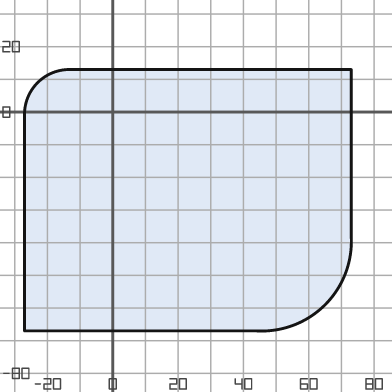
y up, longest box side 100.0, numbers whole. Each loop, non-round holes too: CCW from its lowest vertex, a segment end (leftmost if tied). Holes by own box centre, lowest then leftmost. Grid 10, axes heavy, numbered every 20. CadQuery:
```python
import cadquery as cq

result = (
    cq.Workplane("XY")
    .moveTo(-27.0, -67.0)
    .lineTo(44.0, -67.0)
    .threePointArc((65.0, -59.0), (73.0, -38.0))
    .lineTo(73.0, 13.0)
    .lineTo(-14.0, 13.0)
    .threePointArc((-23.0, 9.0), (-27.0, 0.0))
    .close()
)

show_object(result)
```